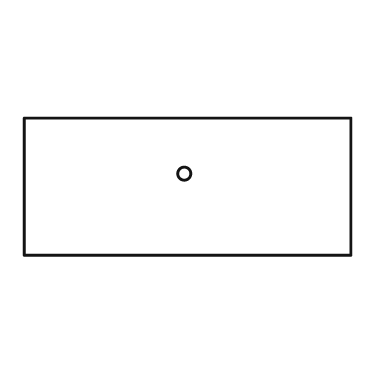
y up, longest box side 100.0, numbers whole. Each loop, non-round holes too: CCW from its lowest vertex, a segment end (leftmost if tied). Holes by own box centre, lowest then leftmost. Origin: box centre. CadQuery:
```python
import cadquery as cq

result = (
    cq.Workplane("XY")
    .moveTo(-50.0, -21.0)
    .lineTo(50.0, -21.0)
    .lineTo(50.0, 21.0)
    .lineTo(-50.0, 21.0)
    .close()
    .moveTo(-1.0, 4.0)
    .circle(2.0)
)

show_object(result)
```